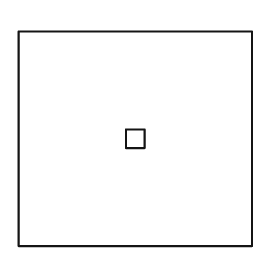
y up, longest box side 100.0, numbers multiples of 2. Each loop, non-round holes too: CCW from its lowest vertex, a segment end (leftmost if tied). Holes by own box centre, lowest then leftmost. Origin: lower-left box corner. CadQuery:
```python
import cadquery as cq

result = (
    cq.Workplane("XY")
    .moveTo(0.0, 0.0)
    .lineTo(100.0, 0.0)
    .lineTo(100.0, 92.0)
    .lineTo(0.0, 92.0)
    .close()
    .moveTo(46.0, 42.0)
    .lineTo(54.0, 42.0)
    .lineTo(54.0, 50.0)
    .lineTo(46.0, 50.0)
    .close()
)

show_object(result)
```